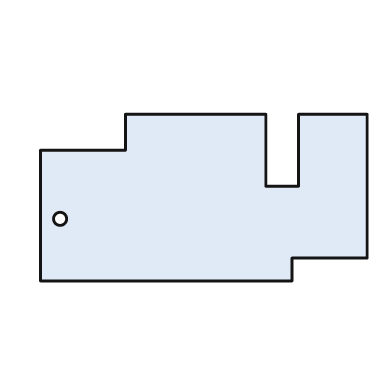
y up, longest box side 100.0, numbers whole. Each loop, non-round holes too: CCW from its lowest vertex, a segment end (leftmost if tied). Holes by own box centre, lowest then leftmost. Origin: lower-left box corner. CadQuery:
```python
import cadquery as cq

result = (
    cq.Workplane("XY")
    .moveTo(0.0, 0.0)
    .lineTo(77.0, 0.0)
    .lineTo(77.0, 7.0)
    .lineTo(100.0, 7.0)
    .lineTo(100.0, 51.0)
    .lineTo(79.0, 51.0)
    .lineTo(79.0, 29.0)
    .lineTo(69.0, 29.0)
    .lineTo(69.0, 51.0)
    .lineTo(26.0, 51.0)
    .lineTo(26.0, 40.0)
    .lineTo(0.0, 40.0)
    .close()
    .moveTo(6.0, 19.0)
    .circle(2.0)
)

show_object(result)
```